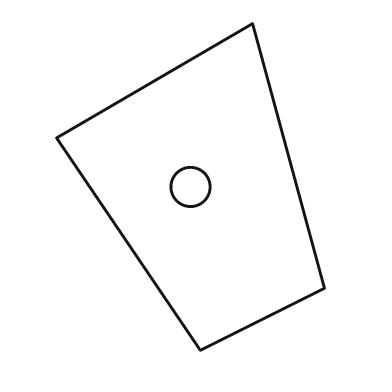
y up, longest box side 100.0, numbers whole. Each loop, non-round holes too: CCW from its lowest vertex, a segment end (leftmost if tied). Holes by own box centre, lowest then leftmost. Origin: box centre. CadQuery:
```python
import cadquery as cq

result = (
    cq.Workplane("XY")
    .moveTo(3.0, -50.0)
    .lineTo(41.0, -31.0)
    .lineTo(19.0, 50.0)
    .lineTo(-41.0, 15.0)
    .close()
    .moveTo(0.0, 0.0)
    .circle(6.0)
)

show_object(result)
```